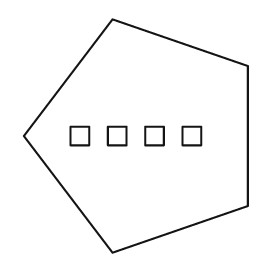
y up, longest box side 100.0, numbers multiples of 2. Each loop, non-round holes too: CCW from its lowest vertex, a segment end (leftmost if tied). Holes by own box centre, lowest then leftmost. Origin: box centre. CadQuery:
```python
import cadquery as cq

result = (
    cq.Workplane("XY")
    .moveTo(-10.0, -50.0)
    .lineTo(48.0, -30.0)
    .lineTo(48.0, 30.0)
    .lineTo(-10.0, 50.0)
    .lineTo(-48.0, 0.0)
    .close()
    .moveTo(-28.0, -4.0)
    .lineTo(-20.0, -4.0)
    .lineTo(-20.0, 4.0)
    .lineTo(-28.0, 4.0)
    .close()
    .moveTo(-12.0, -4.0)
    .lineTo(-4.0, -4.0)
    .lineTo(-4.0, 4.0)
    .lineTo(-12.0, 4.0)
    .close()
    .moveTo(4.0, -4.0)
    .lineTo(12.0, -4.0)
    .lineTo(12.0, 4.0)
    .lineTo(4.0, 4.0)
    .close()
    .moveTo(20.0, -4.0)
    .lineTo(28.0, -4.0)
    .lineTo(28.0, 4.0)
    .lineTo(20.0, 4.0)
    .close()
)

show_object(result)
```